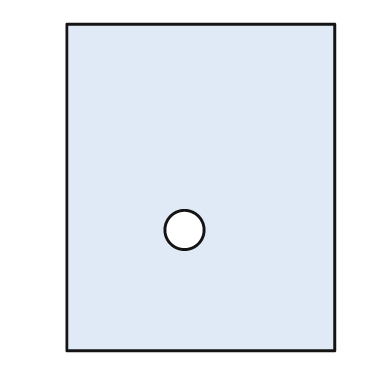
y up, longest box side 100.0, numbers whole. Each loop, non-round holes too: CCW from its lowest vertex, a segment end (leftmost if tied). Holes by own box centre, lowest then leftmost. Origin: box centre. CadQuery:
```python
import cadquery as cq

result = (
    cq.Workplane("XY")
    .moveTo(-41.0, -50.0)
    .lineTo(41.0, -50.0)
    .lineTo(41.0, 50.0)
    .lineTo(-41.0, 50.0)
    .close()
    .moveTo(-5.0, -13.0)
    .circle(6.0)
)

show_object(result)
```